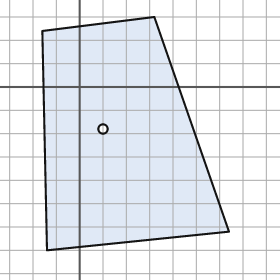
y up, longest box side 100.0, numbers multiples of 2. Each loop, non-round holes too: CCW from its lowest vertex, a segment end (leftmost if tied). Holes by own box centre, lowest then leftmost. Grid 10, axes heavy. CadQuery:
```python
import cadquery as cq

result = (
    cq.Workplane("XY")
    .moveTo(-14.0, -70.0)
    .lineTo(64.0, -62.0)
    .lineTo(32.0, 30.0)
    .lineTo(-16.0, 24.0)
    .close()
    .moveTo(10.0, -18.0)
    .circle(2.0)
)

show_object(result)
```